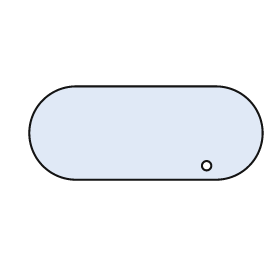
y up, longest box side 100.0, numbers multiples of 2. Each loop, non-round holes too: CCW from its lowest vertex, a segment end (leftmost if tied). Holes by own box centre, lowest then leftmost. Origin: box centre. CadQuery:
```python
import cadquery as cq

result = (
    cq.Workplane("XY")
    .moveTo(-30.0, -20.0)
    .lineTo(30.0, -20.0)
    .threePointArc((50.0, 0.0), (30.0, 20.0))
    .lineTo(-30.0, 20.0)
    .threePointArc((-50.0, 0.0), (-30.0, -20.0))
    .close()
    .moveTo(26.0, -14.0)
    .circle(2.0)
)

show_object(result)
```